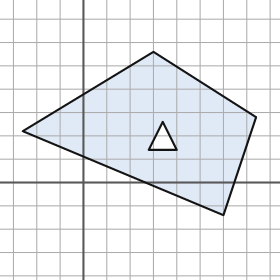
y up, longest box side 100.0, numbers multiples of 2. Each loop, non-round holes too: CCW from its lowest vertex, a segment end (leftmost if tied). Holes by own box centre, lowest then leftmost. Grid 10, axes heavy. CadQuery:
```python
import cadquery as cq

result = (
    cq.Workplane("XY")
    .moveTo(60.0, -14.0)
    .lineTo(74.0, 28.0)
    .lineTo(30.0, 56.0)
    .lineTo(-26.0, 22.0)
    .close()
    .moveTo(28.0, 14.0)
    .lineTo(40.0, 14.0)
    .lineTo(34.0, 26.0)
    .close()
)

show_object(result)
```